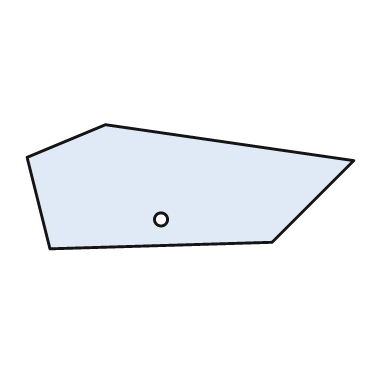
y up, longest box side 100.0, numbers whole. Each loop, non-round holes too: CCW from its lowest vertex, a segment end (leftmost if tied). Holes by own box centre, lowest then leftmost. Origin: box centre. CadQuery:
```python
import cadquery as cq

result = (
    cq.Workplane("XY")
    .moveTo(-43.0, -19.0)
    .lineTo(25.0, -17.0)
    .lineTo(50.0, 8.0)
    .lineTo(-26.0, 19.0)
    .lineTo(-50.0, 9.0)
    .close()
    .moveTo(-9.0, -10.0)
    .circle(2.0)
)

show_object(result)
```